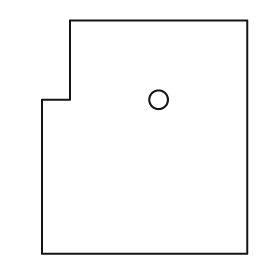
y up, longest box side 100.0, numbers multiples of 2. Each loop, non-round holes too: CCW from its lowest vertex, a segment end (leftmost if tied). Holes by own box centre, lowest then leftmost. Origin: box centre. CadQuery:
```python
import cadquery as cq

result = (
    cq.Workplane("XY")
    .moveTo(-44.0, -50.0)
    .lineTo(44.0, -50.0)
    .lineTo(44.0, 50.0)
    .lineTo(-32.0, 50.0)
    .lineTo(-32.0, 16.0)
    .lineTo(-44.0, 16.0)
    .close()
    .moveTo(6.0, 16.0)
    .circle(4.0)
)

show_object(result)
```